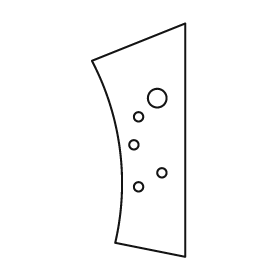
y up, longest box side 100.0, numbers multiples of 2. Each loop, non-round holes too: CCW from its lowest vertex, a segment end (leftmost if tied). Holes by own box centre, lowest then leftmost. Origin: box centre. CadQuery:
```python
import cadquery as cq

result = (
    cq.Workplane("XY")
    .moveTo(20.0, -50.0)
    .lineTo(20.0, 50.0)
    .lineTo(-20.0, 34.0)
    .threePointArc((-8.0, -4.0), (-10.0, -44.0))
    .close()
    .moveTo(0.0, -20.0)
    .circle(2.0)
    .moveTo(10.0, -14.0)
    .circle(2.0)
    .moveTo(-2.0, -2.0)
    .circle(2.0)
    .moveTo(0.0, 10.0)
    .circle(2.0)
    .moveTo(8.0, 18.0)
    .circle(4.0)
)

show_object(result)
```